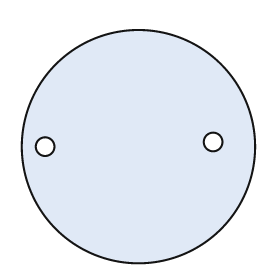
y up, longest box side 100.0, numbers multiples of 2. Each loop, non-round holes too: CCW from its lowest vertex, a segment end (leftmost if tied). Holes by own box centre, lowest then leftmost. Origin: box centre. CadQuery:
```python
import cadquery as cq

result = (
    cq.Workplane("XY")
    .moveTo(0.0, 0.0)
    .circle(50.0)
    .moveTo(-40.0, 0.0)
    .circle(4.0)
    .moveTo(32.0, 2.0)
    .circle(4.0)
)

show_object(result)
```